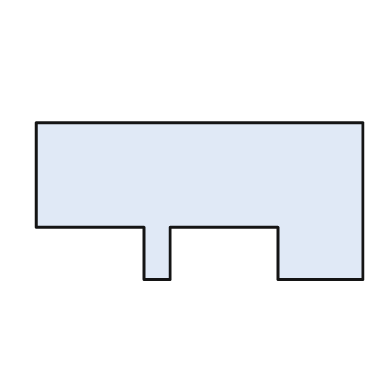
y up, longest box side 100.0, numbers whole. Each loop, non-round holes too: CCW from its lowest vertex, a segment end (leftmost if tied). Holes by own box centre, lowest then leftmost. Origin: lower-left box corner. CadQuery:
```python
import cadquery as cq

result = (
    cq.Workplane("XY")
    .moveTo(33.0, 0.0)
    .lineTo(41.0, 0.0)
    .lineTo(41.0, 16.0)
    .lineTo(74.0, 16.0)
    .lineTo(74.0, 0.0)
    .lineTo(100.0, 0.0)
    .lineTo(100.0, 48.0)
    .lineTo(0.0, 48.0)
    .lineTo(0.0, 16.0)
    .lineTo(33.0, 16.0)
    .close()
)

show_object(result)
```